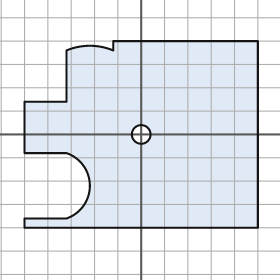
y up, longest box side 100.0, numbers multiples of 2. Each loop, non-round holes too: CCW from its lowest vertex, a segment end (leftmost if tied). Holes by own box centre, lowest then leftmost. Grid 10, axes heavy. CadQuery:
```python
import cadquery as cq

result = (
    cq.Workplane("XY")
    .moveTo(-50.0, -40.0)
    .lineTo(50.0, -40.0)
    .lineTo(50.0, 40.0)
    .lineTo(-12.0, 40.0)
    .lineTo(-12.0, 36.0)
    .threePointArc((-22.0, 38.0), (-32.0, 36.0))
    .lineTo(-32.0, 14.0)
    .lineTo(-50.0, 14.0)
    .lineTo(-50.0, -8.0)
    .lineTo(-32.0, -8.0)
    .threePointArc((-22.0, -22.0), (-32.0, -36.0))
    .lineTo(-50.0, -36.0)
    .close()
    .moveTo(0.0, 0.0)
    .circle(4.0)
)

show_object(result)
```